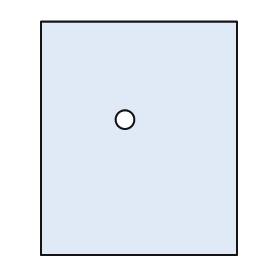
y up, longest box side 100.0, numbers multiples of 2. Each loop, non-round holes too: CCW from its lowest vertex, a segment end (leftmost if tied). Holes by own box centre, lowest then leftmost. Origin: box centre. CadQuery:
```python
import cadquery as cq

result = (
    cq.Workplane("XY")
    .moveTo(-42.0, -50.0)
    .lineTo(42.0, -50.0)
    .lineTo(42.0, 50.0)
    .lineTo(-42.0, 50.0)
    .close()
    .moveTo(-6.0, 8.0)
    .circle(4.0)
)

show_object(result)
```